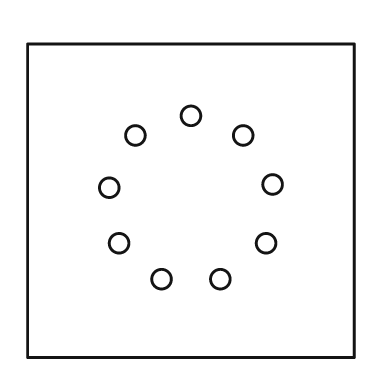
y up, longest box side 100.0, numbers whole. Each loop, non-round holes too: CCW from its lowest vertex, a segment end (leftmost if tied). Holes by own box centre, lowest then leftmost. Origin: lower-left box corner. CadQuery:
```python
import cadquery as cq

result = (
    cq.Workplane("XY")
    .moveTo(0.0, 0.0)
    .lineTo(100.0, 0.0)
    .lineTo(100.0, 96.0)
    .lineTo(0.0, 96.0)
    .close()
    .moveTo(41.0, 24.0)
    .circle(3.0)
    .moveTo(59.0, 24.0)
    .circle(3.0)
    .moveTo(28.0, 35.0)
    .circle(3.0)
    .moveTo(73.0, 35.0)
    .circle(3.0)
    .moveTo(25.0, 52.0)
    .circle(3.0)
    .moveTo(75.0, 53.0)
    .circle(3.0)
    .moveTo(33.0, 68.0)
    .circle(3.0)
    .moveTo(66.0, 68.0)
    .circle(3.0)
    .moveTo(50.0, 74.0)
    .circle(3.0)
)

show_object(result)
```